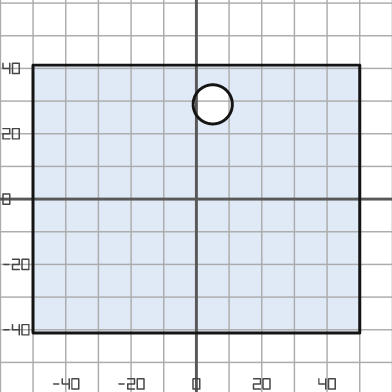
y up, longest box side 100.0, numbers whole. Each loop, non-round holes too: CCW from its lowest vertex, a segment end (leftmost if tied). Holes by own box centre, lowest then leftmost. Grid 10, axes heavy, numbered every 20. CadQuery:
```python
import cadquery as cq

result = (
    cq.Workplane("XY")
    .moveTo(-50.0, -41.0)
    .lineTo(50.0, -41.0)
    .lineTo(50.0, 41.0)
    .lineTo(-50.0, 41.0)
    .close()
    .moveTo(5.0, 29.0)
    .circle(6.0)
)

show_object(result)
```